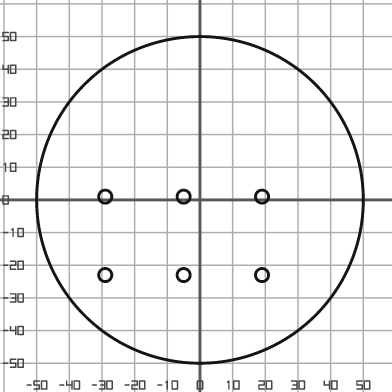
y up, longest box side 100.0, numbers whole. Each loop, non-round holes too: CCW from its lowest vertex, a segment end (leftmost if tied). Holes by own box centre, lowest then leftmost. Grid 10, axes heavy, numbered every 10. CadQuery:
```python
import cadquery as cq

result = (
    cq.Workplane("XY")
    .moveTo(0.0, 0.0)
    .circle(50.0)
    .moveTo(-29.0, -23.0)
    .circle(2.0)
    .moveTo(-5.0, -23.0)
    .circle(2.0)
    .moveTo(19.0, -23.0)
    .circle(2.0)
    .moveTo(-29.0, 1.0)
    .circle(2.0)
    .moveTo(-5.0, 1.0)
    .circle(2.0)
    .moveTo(19.0, 1.0)
    .circle(2.0)
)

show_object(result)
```